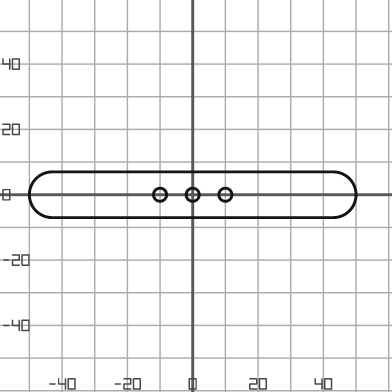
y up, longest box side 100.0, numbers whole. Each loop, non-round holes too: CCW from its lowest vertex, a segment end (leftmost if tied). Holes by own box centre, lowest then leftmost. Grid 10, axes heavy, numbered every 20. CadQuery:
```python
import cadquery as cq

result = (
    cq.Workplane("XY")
    .moveTo(-43.0, -7.0)
    .lineTo(43.0, -7.0)
    .threePointArc((50.0, 0.0), (43.0, 7.0))
    .lineTo(-43.0, 7.0)
    .threePointArc((-50.0, 0.0), (-43.0, -7.0))
    .close()
    .moveTo(-10.0, 0.0)
    .circle(2.0)
    .moveTo(0.0, 0.0)
    .circle(2.0)
    .moveTo(10.0, 0.0)
    .circle(2.0)
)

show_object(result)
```